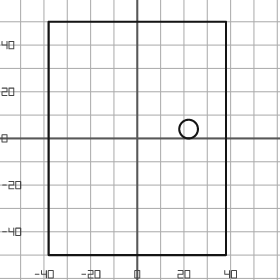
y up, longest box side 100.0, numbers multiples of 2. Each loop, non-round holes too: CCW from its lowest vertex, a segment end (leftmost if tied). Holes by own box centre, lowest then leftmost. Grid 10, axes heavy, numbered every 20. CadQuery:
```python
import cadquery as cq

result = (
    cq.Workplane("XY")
    .moveTo(-38.0, -50.0)
    .lineTo(38.0, -50.0)
    .lineTo(38.0, 50.0)
    .lineTo(-38.0, 50.0)
    .close()
    .moveTo(22.0, 4.0)
    .circle(4.0)
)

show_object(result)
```